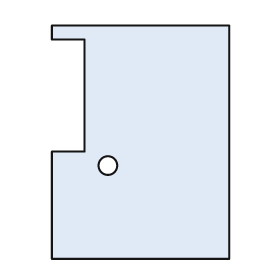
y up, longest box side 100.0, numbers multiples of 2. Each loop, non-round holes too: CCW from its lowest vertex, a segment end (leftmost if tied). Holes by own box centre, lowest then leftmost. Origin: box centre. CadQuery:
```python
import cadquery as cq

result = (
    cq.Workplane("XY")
    .moveTo(-38.0, -50.0)
    .lineTo(38.0, -50.0)
    .lineTo(38.0, 50.0)
    .lineTo(-38.0, 50.0)
    .lineTo(-38.0, 44.0)
    .lineTo(-24.0, 44.0)
    .lineTo(-24.0, -4.0)
    .lineTo(-38.0, -4.0)
    .close()
    .moveTo(-14.0, -10.0)
    .circle(4.0)
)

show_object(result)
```